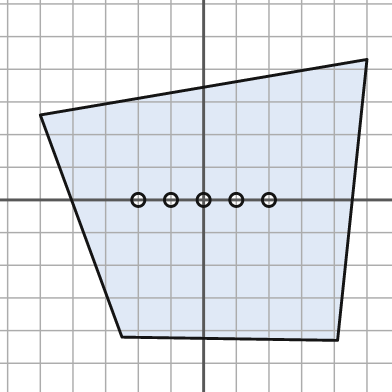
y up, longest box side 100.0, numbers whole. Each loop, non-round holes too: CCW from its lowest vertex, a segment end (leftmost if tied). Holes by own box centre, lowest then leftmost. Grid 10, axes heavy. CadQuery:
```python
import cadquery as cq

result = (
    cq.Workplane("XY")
    .moveTo(41.0, -43.0)
    .lineTo(50.0, 43.0)
    .lineTo(-50.0, 26.0)
    .lineTo(-25.0, -42.0)
    .close()
    .moveTo(-20.0, 0.0)
    .circle(2.0)
    .moveTo(-10.0, 0.0)
    .circle(2.0)
    .moveTo(0.0, 0.0)
    .circle(2.0)
    .moveTo(10.0, 0.0)
    .circle(2.0)
    .moveTo(20.0, 0.0)
    .circle(2.0)
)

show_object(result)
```